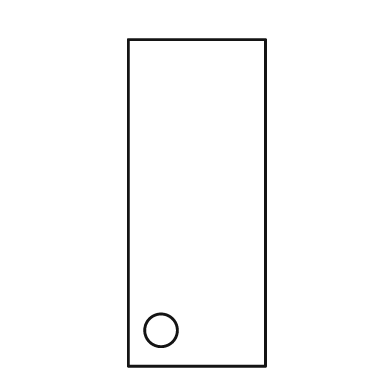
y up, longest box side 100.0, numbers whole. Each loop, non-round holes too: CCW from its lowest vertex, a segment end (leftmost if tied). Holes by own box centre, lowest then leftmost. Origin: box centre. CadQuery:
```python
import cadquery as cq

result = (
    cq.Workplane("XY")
    .moveTo(-21.0, -50.0)
    .lineTo(21.0, -50.0)
    .lineTo(21.0, 50.0)
    .lineTo(-21.0, 50.0)
    .close()
    .moveTo(-11.0, -39.0)
    .circle(5.0)
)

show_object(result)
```